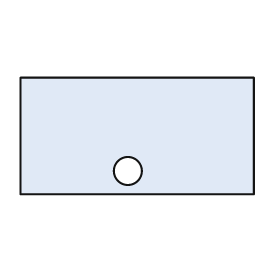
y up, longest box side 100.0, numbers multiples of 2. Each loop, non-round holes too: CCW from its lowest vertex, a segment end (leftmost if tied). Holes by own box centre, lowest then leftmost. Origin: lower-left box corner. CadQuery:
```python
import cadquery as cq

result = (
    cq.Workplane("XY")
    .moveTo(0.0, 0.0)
    .lineTo(100.0, 0.0)
    .lineTo(100.0, 50.0)
    .lineTo(0.0, 50.0)
    .close()
    .moveTo(46.0, 10.0)
    .circle(6.0)
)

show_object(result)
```